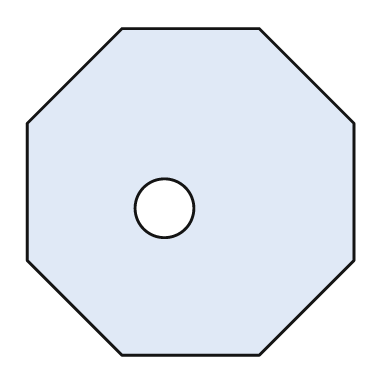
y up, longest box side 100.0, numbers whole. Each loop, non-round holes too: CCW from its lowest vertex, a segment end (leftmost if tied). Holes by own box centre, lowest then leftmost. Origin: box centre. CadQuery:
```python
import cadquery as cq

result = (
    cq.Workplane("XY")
    .moveTo(-21.0, -50.0)
    .lineTo(21.0, -50.0)
    .lineTo(50.0, -21.0)
    .lineTo(50.0, 21.0)
    .lineTo(21.0, 50.0)
    .lineTo(-21.0, 50.0)
    .lineTo(-50.0, 21.0)
    .lineTo(-50.0, -21.0)
    .close()
    .moveTo(-8.0, -5.0)
    .circle(9.0)
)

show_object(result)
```